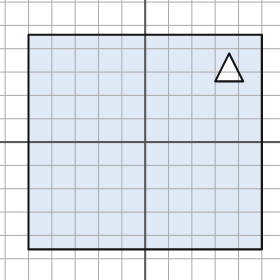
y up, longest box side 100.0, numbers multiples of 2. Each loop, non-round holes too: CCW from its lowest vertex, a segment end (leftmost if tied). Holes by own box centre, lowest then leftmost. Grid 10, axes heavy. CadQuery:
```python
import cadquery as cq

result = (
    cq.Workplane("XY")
    .moveTo(-50.0, -46.0)
    .lineTo(50.0, -46.0)
    .lineTo(50.0, 46.0)
    .lineTo(-50.0, 46.0)
    .close()
    .moveTo(30.0, 26.0)
    .lineTo(42.0, 26.0)
    .lineTo(36.0, 38.0)
    .close()
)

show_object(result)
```